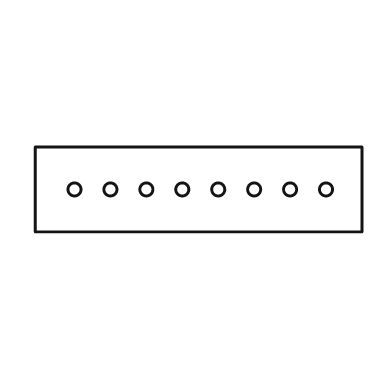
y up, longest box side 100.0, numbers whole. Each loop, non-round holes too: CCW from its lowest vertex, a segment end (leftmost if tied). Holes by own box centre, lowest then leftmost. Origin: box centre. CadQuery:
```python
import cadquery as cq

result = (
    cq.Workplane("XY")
    .moveTo(-50.0, -13.0)
    .lineTo(50.0, -13.0)
    .lineTo(50.0, 13.0)
    .lineTo(-50.0, 13.0)
    .close()
    .moveTo(-38.0, 0.0)
    .circle(2.0)
    .moveTo(-27.0, 0.0)
    .circle(2.0)
    .moveTo(-16.0, 0.0)
    .circle(2.0)
    .moveTo(-5.0, 0.0)
    .circle(2.0)
    .moveTo(6.0, 0.0)
    .circle(2.0)
    .moveTo(17.0, 0.0)
    .circle(2.0)
    .moveTo(28.0, 0.0)
    .circle(2.0)
    .moveTo(39.0, 0.0)
    .circle(2.0)
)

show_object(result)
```